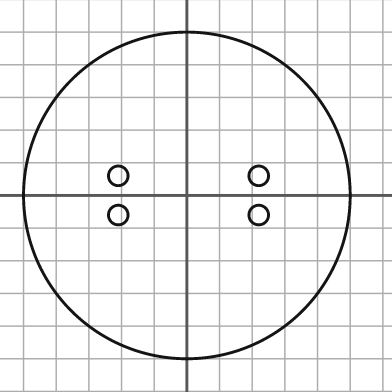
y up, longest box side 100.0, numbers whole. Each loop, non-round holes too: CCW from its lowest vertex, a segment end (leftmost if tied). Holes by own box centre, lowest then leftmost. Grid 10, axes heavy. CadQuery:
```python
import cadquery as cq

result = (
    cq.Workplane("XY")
    .moveTo(0.0, 0.0)
    .circle(50.0)
    .moveTo(-21.0, -6.0)
    .circle(3.0)
    .moveTo(22.0, -6.0)
    .circle(3.0)
    .moveTo(-21.0, 6.0)
    .circle(3.0)
    .moveTo(22.0, 6.0)
    .circle(3.0)
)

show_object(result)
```